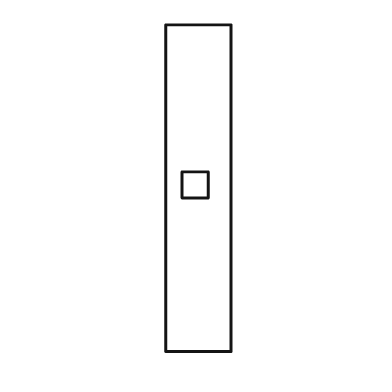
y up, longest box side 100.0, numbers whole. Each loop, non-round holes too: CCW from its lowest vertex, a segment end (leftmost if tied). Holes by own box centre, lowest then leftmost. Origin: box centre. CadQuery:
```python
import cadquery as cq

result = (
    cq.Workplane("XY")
    .moveTo(-10.0, -50.0)
    .lineTo(10.0, -50.0)
    .lineTo(10.0, 50.0)
    .lineTo(-10.0, 50.0)
    .close()
    .moveTo(-5.0, -3.0)
    .lineTo(3.0, -3.0)
    .lineTo(3.0, 5.0)
    .lineTo(-5.0, 5.0)
    .close()
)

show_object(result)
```